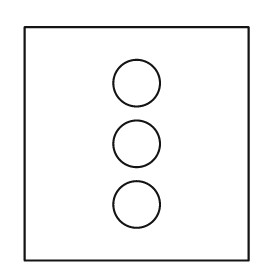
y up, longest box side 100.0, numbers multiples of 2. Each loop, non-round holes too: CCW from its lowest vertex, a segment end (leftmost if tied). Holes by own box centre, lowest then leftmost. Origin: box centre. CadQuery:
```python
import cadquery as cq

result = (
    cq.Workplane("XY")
    .moveTo(-48.0, -50.0)
    .lineTo(48.0, -50.0)
    .lineTo(48.0, 50.0)
    .lineTo(-48.0, 50.0)
    .close()
    .moveTo(0.0, -26.0)
    .circle(10.0)
    .moveTo(0.0, 0.0)
    .circle(10.0)
    .moveTo(0.0, 26.0)
    .circle(10.0)
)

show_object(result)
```